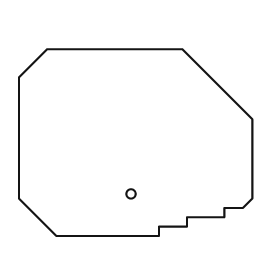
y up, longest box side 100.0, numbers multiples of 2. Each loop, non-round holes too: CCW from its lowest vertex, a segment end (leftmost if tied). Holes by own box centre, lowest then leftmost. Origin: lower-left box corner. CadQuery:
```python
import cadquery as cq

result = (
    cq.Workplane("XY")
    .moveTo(16.0, 0.0)
    .lineTo(60.0, 0.0)
    .lineTo(60.0, 4.0)
    .lineTo(72.0, 4.0)
    .lineTo(72.0, 8.0)
    .lineTo(88.0, 8.0)
    .lineTo(88.0, 12.0)
    .lineTo(96.0, 12.0)
    .lineTo(100.0, 16.0)
    .lineTo(100.0, 50.0)
    .lineTo(70.0, 80.0)
    .lineTo(12.0, 80.0)
    .lineTo(0.0, 68.0)
    .lineTo(0.0, 16.0)
    .close()
    .moveTo(48.0, 18.0)
    .circle(2.0)
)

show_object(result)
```